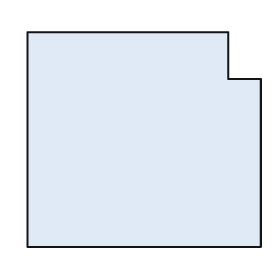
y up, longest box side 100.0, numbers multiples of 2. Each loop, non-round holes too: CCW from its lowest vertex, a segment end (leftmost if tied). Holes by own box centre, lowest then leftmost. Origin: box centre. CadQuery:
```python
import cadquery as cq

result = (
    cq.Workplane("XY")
    .moveTo(-50.0, -46.0)
    .lineTo(50.0, -46.0)
    .lineTo(50.0, 26.0)
    .lineTo(36.0, 26.0)
    .lineTo(36.0, 46.0)
    .lineTo(-50.0, 46.0)
    .close()
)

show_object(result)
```